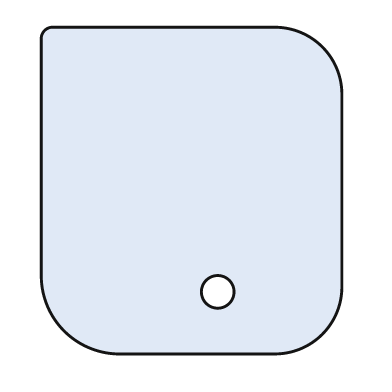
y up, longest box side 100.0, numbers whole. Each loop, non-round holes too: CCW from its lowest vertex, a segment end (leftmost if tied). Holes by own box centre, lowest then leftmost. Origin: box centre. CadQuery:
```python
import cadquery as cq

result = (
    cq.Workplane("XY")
    .moveTo(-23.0, -50.0)
    .lineTo(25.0, -50.0)
    .threePointArc((40.0, -44.0), (46.0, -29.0))
    .lineTo(46.0, 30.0)
    .threePointArc((40.0, 44.0), (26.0, 50.0))
    .lineTo(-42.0, 50.0)
    .threePointArc((-45.0, 49.0), (-46.0, 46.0))
    .lineTo(-46.0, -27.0)
    .threePointArc((-39.0, -43.0), (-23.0, -50.0))
    .close()
    .moveTo(8.0, -31.0)
    .circle(5.0)
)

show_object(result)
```